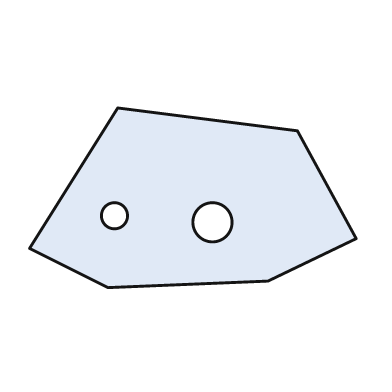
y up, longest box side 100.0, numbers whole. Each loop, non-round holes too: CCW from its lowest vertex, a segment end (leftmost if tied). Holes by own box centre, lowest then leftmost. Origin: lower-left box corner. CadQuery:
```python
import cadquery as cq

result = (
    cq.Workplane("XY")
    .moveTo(24.0, 0.0)
    .lineTo(73.0, 2.0)
    .lineTo(100.0, 15.0)
    .lineTo(82.0, 48.0)
    .lineTo(27.0, 55.0)
    .lineTo(0.0, 12.0)
    .close()
    .moveTo(56.0, 20.0)
    .circle(6.0)
    .moveTo(26.0, 22.0)
    .circle(4.0)
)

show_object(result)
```